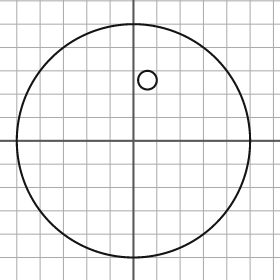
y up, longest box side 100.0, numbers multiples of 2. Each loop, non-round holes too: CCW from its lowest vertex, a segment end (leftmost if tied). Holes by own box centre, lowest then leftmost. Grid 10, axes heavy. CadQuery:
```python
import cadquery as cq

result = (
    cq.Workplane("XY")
    .moveTo(0.0, 0.0)
    .circle(50.0)
    .moveTo(6.0, 26.0)
    .circle(4.0)
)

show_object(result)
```